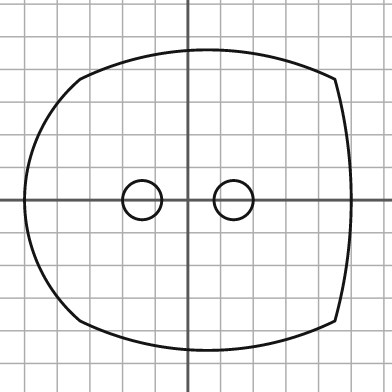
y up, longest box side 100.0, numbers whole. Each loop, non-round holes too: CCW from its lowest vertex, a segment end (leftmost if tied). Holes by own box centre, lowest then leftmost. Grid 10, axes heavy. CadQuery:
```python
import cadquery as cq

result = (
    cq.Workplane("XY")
    .moveTo(-33.0, -37.0)
    .threePointArc((6.0, -46.0), (45.0, -37.0))
    .threePointArc((50.0, 0.0), (45.0, 37.0))
    .threePointArc((6.0, 46.0), (-33.0, 37.0))
    .threePointArc((-50.0, 0.0), (-33.0, -37.0))
    .close()
    .moveTo(-14.0, 0.0)
    .circle(6.0)
    .moveTo(14.0, 0.0)
    .circle(6.0)
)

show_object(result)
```